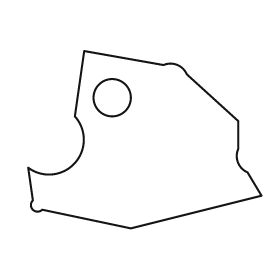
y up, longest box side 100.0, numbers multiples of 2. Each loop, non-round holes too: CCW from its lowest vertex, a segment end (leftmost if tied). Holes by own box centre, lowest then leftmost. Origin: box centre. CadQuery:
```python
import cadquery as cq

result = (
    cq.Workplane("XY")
    .moveTo(-6.0, -38.0)
    .lineTo(50.0, -24.0)
    .lineTo(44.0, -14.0)
    .threePointArc((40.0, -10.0), (40.0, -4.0))
    .lineTo(40.0, 8.0)
    .lineTo(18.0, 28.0)
    .threePointArc((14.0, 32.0), (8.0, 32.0))
    .lineTo(-26.0, 38.0)
    .lineTo(-30.0, 10.0)
    .threePointArc((-30.0, -10.0), (-50.0, -12.0))
    .lineTo(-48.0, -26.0)
    .threePointArc((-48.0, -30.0), (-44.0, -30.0))
    .close()
    .moveTo(-14.0, 18.0)
    .circle(8.0)
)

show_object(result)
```